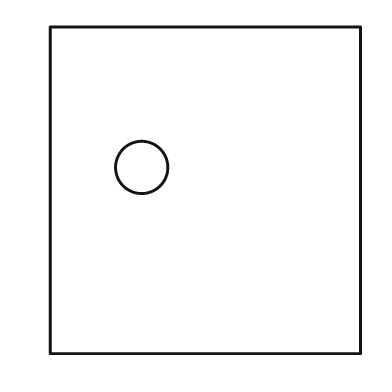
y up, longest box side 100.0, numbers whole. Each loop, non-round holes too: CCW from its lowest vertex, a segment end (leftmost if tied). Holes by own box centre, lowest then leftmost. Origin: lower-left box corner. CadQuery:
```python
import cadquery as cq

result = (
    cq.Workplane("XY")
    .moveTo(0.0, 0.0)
    .lineTo(95.0, 0.0)
    .lineTo(95.0, 100.0)
    .lineTo(0.0, 100.0)
    .close()
    .moveTo(28.0, 57.0)
    .circle(8.0)
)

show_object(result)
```